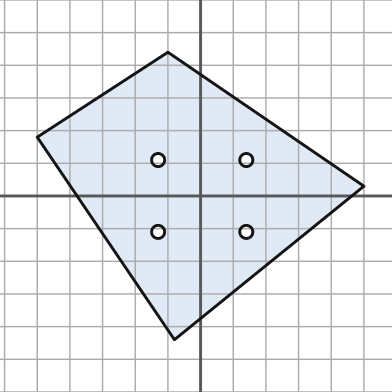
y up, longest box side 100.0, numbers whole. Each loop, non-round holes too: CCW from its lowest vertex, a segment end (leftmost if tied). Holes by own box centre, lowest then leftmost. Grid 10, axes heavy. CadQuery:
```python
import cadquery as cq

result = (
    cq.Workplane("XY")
    .moveTo(-8.0, -44.0)
    .lineTo(50.0, 3.0)
    .lineTo(-10.0, 44.0)
    .lineTo(-50.0, 18.0)
    .close()
    .moveTo(-13.0, -11.0)
    .circle(2.0)
    .moveTo(14.0, -11.0)
    .circle(2.0)
    .moveTo(-13.0, 11.0)
    .circle(2.0)
    .moveTo(14.0, 11.0)
    .circle(2.0)
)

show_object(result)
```